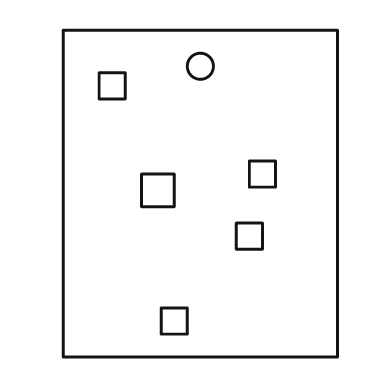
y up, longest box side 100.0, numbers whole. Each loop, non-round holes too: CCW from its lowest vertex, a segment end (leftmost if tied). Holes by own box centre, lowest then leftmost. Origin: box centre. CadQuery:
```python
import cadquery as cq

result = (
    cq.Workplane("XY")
    .moveTo(-42.0, -50.0)
    .lineTo(42.0, -50.0)
    .lineTo(42.0, 50.0)
    .lineTo(-42.0, 50.0)
    .close()
    .moveTo(-12.0, -43.0)
    .lineTo(-4.0, -43.0)
    .lineTo(-4.0, -35.0)
    .lineTo(-12.0, -35.0)
    .close()
    .moveTo(11.0, -17.0)
    .lineTo(19.0, -17.0)
    .lineTo(19.0, -9.0)
    .lineTo(11.0, -9.0)
    .close()
    .moveTo(-18.0, -4.0)
    .lineTo(-8.0, -4.0)
    .lineTo(-8.0, 6.0)
    .lineTo(-18.0, 6.0)
    .close()
    .moveTo(15.0, 2.0)
    .lineTo(23.0, 2.0)
    .lineTo(23.0, 10.0)
    .lineTo(15.0, 10.0)
    .close()
    .moveTo(-31.0, 29.0)
    .lineTo(-23.0, 29.0)
    .lineTo(-23.0, 37.0)
    .lineTo(-31.0, 37.0)
    .close()
    .moveTo(0.0, 39.0)
    .circle(4.0)
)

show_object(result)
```